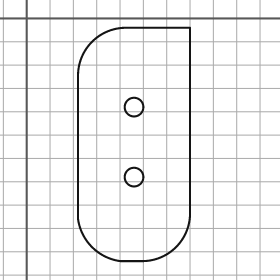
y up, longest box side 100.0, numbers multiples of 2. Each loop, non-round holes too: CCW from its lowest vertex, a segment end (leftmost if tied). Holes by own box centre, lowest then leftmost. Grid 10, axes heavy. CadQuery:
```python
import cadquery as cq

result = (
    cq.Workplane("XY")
    .moveTo(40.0, -104.0)
    .lineTo(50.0, -104.0)
    .threePointArc((64.0, -98.0), (70.0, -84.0))
    .lineTo(70.0, -4.0)
    .lineTo(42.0, -4.0)
    .threePointArc((28.0, -10.0), (22.0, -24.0))
    .lineTo(22.0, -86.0)
    .threePointArc((28.0, -98.0), (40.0, -104.0))
    .close()
    .moveTo(46.0, -68.0)
    .circle(4.0)
    .moveTo(46.0, -38.0)
    .circle(4.0)
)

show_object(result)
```